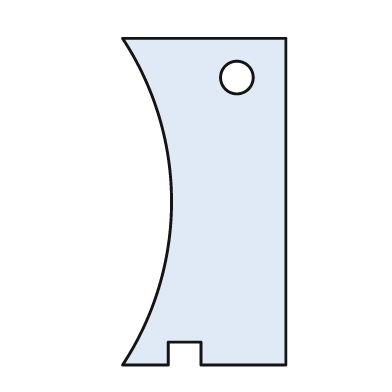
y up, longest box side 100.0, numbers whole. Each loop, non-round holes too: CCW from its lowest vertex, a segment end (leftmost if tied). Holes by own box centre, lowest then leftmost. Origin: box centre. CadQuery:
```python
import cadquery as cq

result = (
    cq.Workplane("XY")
    .moveTo(-25.0, -50.0)
    .lineTo(-11.0, -50.0)
    .lineTo(-11.0, -43.0)
    .lineTo(-1.0, -43.0)
    .lineTo(-1.0, -50.0)
    .lineTo(25.0, -50.0)
    .lineTo(25.0, 50.0)
    .lineTo(-25.0, 50.0)
    .threePointArc((-10.0, 0.0), (-25.0, -50.0))
    .close()
    .moveTo(10.0, 38.0)
    .circle(5.0)
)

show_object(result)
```